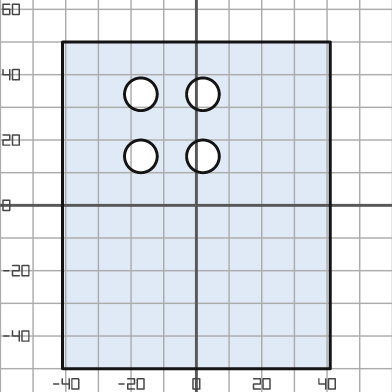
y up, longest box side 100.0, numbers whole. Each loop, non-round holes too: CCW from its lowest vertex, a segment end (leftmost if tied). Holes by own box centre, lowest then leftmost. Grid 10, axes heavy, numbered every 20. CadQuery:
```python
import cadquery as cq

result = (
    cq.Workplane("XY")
    .moveTo(-41.0, -50.0)
    .lineTo(41.0, -50.0)
    .lineTo(41.0, 50.0)
    .lineTo(-41.0, 50.0)
    .close()
    .moveTo(-17.0, 15.0)
    .circle(5.0)
    .moveTo(2.0, 15.0)
    .circle(5.0)
    .moveTo(-17.0, 34.0)
    .circle(5.0)
    .moveTo(2.0, 34.0)
    .circle(5.0)
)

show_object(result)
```